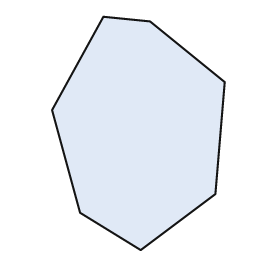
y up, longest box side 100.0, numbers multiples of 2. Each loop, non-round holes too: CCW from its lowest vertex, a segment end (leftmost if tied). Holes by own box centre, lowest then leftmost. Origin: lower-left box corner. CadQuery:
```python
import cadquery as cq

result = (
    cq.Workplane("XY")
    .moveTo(38.0, 0.0)
    .lineTo(70.0, 24.0)
    .lineTo(74.0, 72.0)
    .lineTo(42.0, 98.0)
    .lineTo(22.0, 100.0)
    .lineTo(0.0, 60.0)
    .lineTo(12.0, 16.0)
    .close()
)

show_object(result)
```